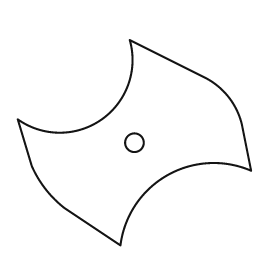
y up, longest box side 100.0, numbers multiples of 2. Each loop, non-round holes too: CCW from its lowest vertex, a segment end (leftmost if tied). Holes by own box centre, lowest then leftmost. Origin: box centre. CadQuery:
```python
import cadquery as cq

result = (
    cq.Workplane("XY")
    .moveTo(-6.0, -44.0)
    .threePointArc((14.0, -14.0), (50.0, -12.0))
    .lineTo(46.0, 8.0)
    .threePointArc((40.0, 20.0), (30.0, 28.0))
    .lineTo(-2.0, 44.0)
    .threePointArc((-14.0, 10.0), (-50.0, 10.0))
    .lineTo(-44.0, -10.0)
    .threePointArc((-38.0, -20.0), (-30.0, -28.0))
    .close()
    .moveTo(0.0, 0.0)
    .circle(4.0)
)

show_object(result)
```